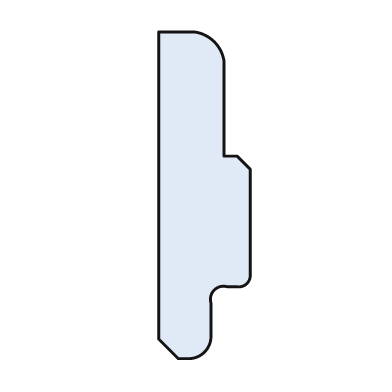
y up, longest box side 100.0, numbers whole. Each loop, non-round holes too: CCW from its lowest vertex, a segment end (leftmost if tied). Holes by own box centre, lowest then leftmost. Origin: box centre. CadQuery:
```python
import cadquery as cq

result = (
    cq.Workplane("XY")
    .moveTo(-8.0, -50.0)
    .lineTo(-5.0, -50.0)
    .threePointArc((0.0, -48.0), (2.0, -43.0))
    .lineTo(2.0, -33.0)
    .threePointArc((3.0, -29.0), (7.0, -28.0))
    .lineTo(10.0, -28.0)
    .threePointArc((13.0, -27.0), (14.0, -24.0))
    .lineTo(14.0, 8.0)
    .lineTo(10.0, 12.0)
    .lineTo(6.0, 12.0)
    .lineTo(6.0, 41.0)
    .threePointArc((3.0, 47.0), (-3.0, 50.0))
    .lineTo(-14.0, 50.0)
    .lineTo(-14.0, -44.0)
    .close()
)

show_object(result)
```